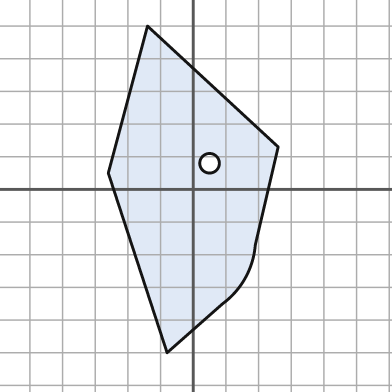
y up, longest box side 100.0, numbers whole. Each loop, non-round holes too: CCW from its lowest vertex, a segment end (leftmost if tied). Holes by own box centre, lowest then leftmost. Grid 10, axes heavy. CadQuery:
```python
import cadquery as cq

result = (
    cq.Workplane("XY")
    .moveTo(-8.0, -50.0)
    .lineTo(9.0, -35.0)
    .threePointArc((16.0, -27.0), (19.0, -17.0))
    .lineTo(26.0, 13.0)
    .lineTo(-14.0, 50.0)
    .lineTo(-26.0, 5.0)
    .close()
    .moveTo(5.0, 8.0)
    .circle(3.0)
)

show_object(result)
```